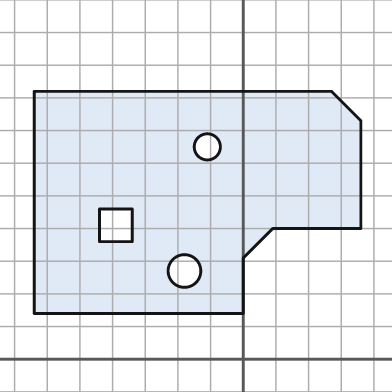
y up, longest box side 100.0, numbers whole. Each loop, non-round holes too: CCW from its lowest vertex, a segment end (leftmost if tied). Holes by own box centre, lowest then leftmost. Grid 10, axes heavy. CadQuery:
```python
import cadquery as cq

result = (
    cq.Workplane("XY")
    .moveTo(-64.0, 14.0)
    .lineTo(0.0, 14.0)
    .lineTo(0.0, 31.0)
    .lineTo(9.0, 40.0)
    .lineTo(36.0, 40.0)
    .lineTo(36.0, 73.0)
    .lineTo(27.0, 82.0)
    .lineTo(-64.0, 82.0)
    .close()
    .moveTo(-18.0, 27.0)
    .circle(5.0)
    .moveTo(-44.0, 36.0)
    .lineTo(-34.0, 36.0)
    .lineTo(-34.0, 46.0)
    .lineTo(-44.0, 46.0)
    .close()
    .moveTo(-11.0, 65.0)
    .circle(4.0)
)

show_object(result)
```